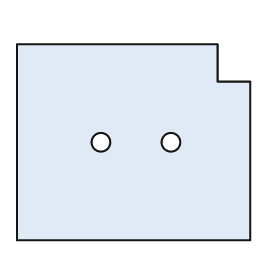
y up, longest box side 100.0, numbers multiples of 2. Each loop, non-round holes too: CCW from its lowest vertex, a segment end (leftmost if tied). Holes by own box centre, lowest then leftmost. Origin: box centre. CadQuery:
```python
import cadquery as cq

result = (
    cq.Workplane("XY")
    .moveTo(-50.0, -42.0)
    .lineTo(50.0, -42.0)
    .lineTo(50.0, 26.0)
    .lineTo(36.0, 26.0)
    .lineTo(36.0, 42.0)
    .lineTo(-50.0, 42.0)
    .close()
    .moveTo(-14.0, 0.0)
    .circle(4.0)
    .moveTo(16.0, 0.0)
    .circle(4.0)
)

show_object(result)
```